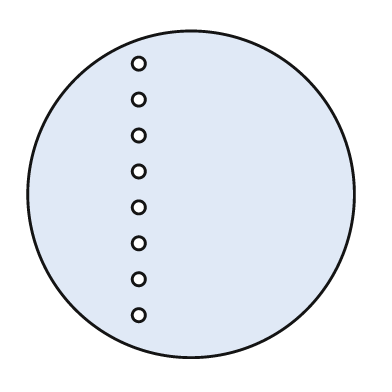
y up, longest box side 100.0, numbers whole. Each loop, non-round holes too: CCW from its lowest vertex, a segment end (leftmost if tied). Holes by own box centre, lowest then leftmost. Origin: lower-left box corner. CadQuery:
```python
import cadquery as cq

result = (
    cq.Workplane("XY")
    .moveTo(50.0, 50.0)
    .circle(50.0)
    .moveTo(34.0, 13.0)
    .circle(2.0)
    .moveTo(34.0, 24.0)
    .circle(2.0)
    .moveTo(34.0, 35.0)
    .circle(2.0)
    .moveTo(34.0, 46.0)
    .circle(2.0)
    .moveTo(34.0, 57.0)
    .circle(2.0)
    .moveTo(34.0, 68.0)
    .circle(2.0)
    .moveTo(34.0, 79.0)
    .circle(2.0)
    .moveTo(34.0, 90.0)
    .circle(2.0)
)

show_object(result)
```